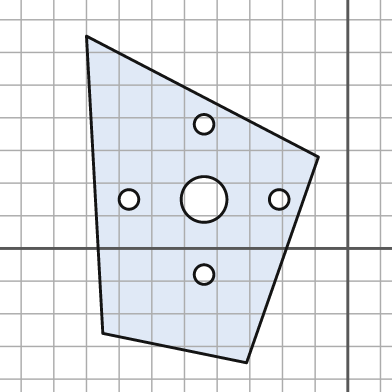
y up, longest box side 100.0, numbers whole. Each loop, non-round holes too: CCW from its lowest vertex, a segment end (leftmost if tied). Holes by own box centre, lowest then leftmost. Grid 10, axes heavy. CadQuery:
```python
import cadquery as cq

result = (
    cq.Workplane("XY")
    .moveTo(-31.0, -35.0)
    .lineTo(-9.0, 28.0)
    .lineTo(-80.0, 65.0)
    .lineTo(-75.0, -26.0)
    .close()
    .moveTo(-44.0, -8.0)
    .circle(3.0)
    .moveTo(-67.0, 15.0)
    .circle(3.0)
    .moveTo(-44.0, 15.0)
    .circle(7.0)
    .moveTo(-21.0, 15.0)
    .circle(3.0)
    .moveTo(-44.0, 38.0)
    .circle(3.0)
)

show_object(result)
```